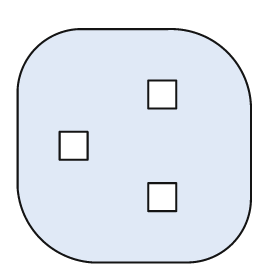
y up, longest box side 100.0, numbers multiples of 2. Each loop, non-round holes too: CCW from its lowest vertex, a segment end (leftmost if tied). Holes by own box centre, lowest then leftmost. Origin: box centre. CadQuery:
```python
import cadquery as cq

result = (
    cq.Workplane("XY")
    .moveTo(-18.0, -50.0)
    .lineTo(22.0, -50.0)
    .threePointArc((42.0, -42.0), (50.0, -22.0))
    .lineTo(50.0, 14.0)
    .threePointArc((40.0, 40.0), (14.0, 50.0))
    .lineTo(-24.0, 50.0)
    .threePointArc((-42.0, 42.0), (-50.0, 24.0))
    .lineTo(-50.0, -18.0)
    .threePointArc((-40.0, -40.0), (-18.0, -50.0))
    .close()
    .moveTo(6.0, -28.0)
    .lineTo(18.0, -28.0)
    .lineTo(18.0, -16.0)
    .lineTo(6.0, -16.0)
    .close()
    .moveTo(-32.0, -6.0)
    .lineTo(-20.0, -6.0)
    .lineTo(-20.0, 6.0)
    .lineTo(-32.0, 6.0)
    .close()
    .moveTo(6.0, 16.0)
    .lineTo(18.0, 16.0)
    .lineTo(18.0, 28.0)
    .lineTo(6.0, 28.0)
    .close()
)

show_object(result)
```